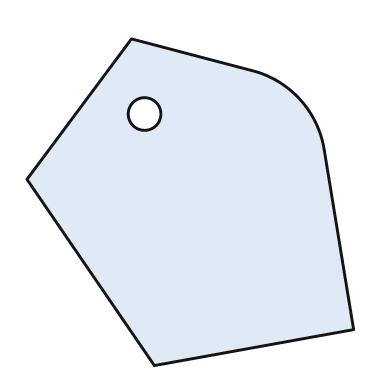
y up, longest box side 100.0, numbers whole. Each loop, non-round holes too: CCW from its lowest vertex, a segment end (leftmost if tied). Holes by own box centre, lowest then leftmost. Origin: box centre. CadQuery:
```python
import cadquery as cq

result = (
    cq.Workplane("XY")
    .moveTo(-11.0, -50.0)
    .lineTo(50.0, -39.0)
    .lineTo(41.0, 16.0)
    .threePointArc((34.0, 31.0), (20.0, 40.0))
    .lineTo(-18.0, 50.0)
    .lineTo(-50.0, 7.0)
    .close()
    .moveTo(-14.0, 27.0)
    .circle(5.0)
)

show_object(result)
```